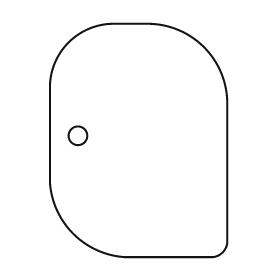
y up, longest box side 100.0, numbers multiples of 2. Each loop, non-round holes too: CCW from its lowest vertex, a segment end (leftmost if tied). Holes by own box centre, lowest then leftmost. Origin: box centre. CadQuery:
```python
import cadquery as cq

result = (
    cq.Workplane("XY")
    .moveTo(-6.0, -50.0)
    .lineTo(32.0, -50.0)
    .threePointArc((36.0, -48.0), (38.0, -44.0))
    .lineTo(38.0, 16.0)
    .threePointArc((28.0, 40.0), (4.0, 50.0))
    .lineTo(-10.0, 50.0)
    .threePointArc((-30.0, 42.0), (-38.0, 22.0))
    .lineTo(-38.0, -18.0)
    .threePointArc((-28.0, -40.0), (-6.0, -50.0))
    .close()
    .moveTo(-26.0, 2.0)
    .circle(4.0)
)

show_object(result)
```